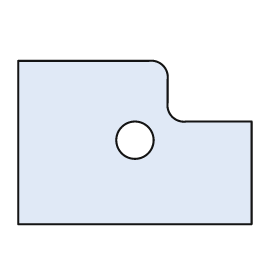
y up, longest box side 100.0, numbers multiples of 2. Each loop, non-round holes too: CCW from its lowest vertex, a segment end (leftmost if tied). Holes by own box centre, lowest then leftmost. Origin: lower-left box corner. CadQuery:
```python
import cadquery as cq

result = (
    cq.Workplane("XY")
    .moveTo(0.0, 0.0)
    .lineTo(100.0, 0.0)
    .lineTo(100.0, 44.0)
    .lineTo(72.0, 44.0)
    .threePointArc((66.0, 46.0), (64.0, 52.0))
    .lineTo(64.0, 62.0)
    .threePointArc((62.0, 68.0), (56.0, 70.0))
    .lineTo(0.0, 70.0)
    .close()
    .moveTo(50.0, 36.0)
    .circle(8.0)
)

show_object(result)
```